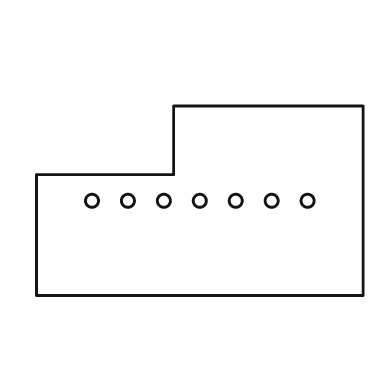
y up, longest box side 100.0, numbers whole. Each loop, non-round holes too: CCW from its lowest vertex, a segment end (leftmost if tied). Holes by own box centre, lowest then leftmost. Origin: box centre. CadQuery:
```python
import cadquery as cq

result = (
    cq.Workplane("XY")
    .moveTo(-50.0, -29.0)
    .lineTo(50.0, -29.0)
    .lineTo(50.0, 29.0)
    .lineTo(-8.0, 29.0)
    .lineTo(-8.0, 8.0)
    .lineTo(-50.0, 8.0)
    .close()
    .moveTo(-33.0, 0.0)
    .circle(2.0)
    .moveTo(-22.0, 0.0)
    .circle(2.0)
    .moveTo(-11.0, 0.0)
    .circle(2.0)
    .moveTo(0.0, 0.0)
    .circle(2.0)
    .moveTo(11.0, 0.0)
    .circle(2.0)
    .moveTo(22.0, 0.0)
    .circle(2.0)
    .moveTo(33.0, 0.0)
    .circle(2.0)
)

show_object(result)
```